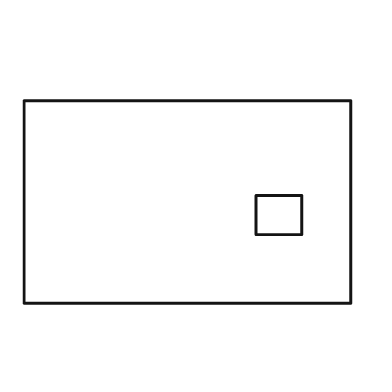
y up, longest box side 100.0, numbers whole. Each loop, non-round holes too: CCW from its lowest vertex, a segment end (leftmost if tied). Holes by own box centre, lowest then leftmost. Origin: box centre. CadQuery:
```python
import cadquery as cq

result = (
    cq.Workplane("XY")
    .moveTo(-50.0, -31.0)
    .lineTo(50.0, -31.0)
    .lineTo(50.0, 31.0)
    .lineTo(-50.0, 31.0)
    .close()
    .moveTo(21.0, -10.0)
    .lineTo(35.0, -10.0)
    .lineTo(35.0, 2.0)
    .lineTo(21.0, 2.0)
    .close()
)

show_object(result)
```